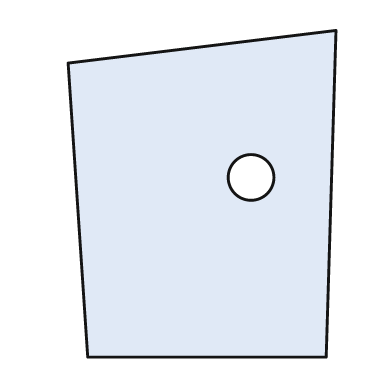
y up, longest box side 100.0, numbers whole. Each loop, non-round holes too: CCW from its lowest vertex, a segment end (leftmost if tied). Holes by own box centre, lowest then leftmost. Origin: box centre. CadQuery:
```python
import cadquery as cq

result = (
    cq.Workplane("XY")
    .moveTo(-35.0, -50.0)
    .lineTo(38.0, -50.0)
    .lineTo(41.0, 50.0)
    .lineTo(-41.0, 40.0)
    .close()
    .moveTo(15.0, 5.0)
    .circle(7.0)
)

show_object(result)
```